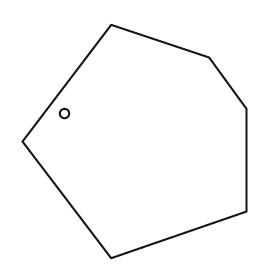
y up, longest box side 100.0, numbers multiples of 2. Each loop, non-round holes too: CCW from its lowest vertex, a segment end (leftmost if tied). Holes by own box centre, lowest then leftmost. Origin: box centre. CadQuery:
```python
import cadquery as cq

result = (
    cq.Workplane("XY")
    .moveTo(-10.0, -50.0)
    .lineTo(48.0, -30.0)
    .lineTo(48.0, 14.0)
    .lineTo(32.0, 36.0)
    .lineTo(-10.0, 50.0)
    .lineTo(-48.0, 0.0)
    .close()
    .moveTo(-30.0, 12.0)
    .circle(2.0)
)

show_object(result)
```